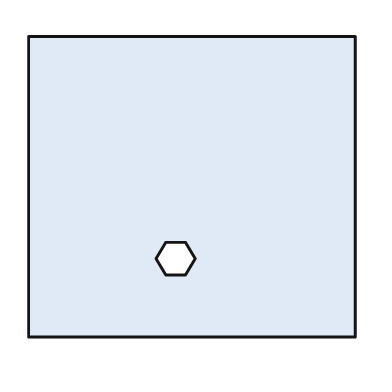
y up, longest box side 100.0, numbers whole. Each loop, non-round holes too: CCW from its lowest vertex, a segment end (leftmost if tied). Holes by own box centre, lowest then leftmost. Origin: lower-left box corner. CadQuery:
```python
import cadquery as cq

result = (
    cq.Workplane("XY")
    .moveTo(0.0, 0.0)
    .lineTo(100.0, 0.0)
    .lineTo(100.0, 92.0)
    .lineTo(0.0, 92.0)
    .close()
    .moveTo(42.0, 19.0)
    .lineTo(48.0, 19.0)
    .lineTo(51.0, 24.0)
    .lineTo(48.0, 29.0)
    .lineTo(42.0, 29.0)
    .lineTo(39.0, 24.0)
    .close()
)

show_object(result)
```